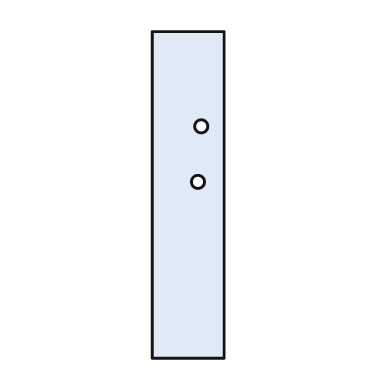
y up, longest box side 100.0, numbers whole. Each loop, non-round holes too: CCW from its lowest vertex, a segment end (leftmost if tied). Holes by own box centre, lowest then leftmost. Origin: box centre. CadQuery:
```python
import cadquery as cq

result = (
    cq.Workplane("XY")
    .moveTo(-11.0, -50.0)
    .lineTo(11.0, -50.0)
    .lineTo(11.0, 50.0)
    .lineTo(-11.0, 50.0)
    .close()
    .moveTo(3.0, 4.0)
    .circle(2.0)
    .moveTo(4.0, 21.0)
    .circle(2.0)
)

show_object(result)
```